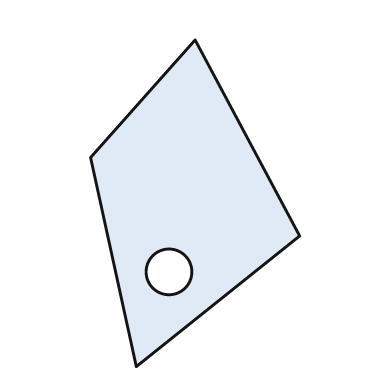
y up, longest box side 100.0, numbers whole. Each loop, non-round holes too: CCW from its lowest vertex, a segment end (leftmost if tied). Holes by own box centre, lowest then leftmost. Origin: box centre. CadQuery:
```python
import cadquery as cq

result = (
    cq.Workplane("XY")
    .moveTo(-18.0, -50.0)
    .lineTo(32.0, -10.0)
    .lineTo(0.0, 50.0)
    .lineTo(-32.0, 14.0)
    .close()
    .moveTo(-8.0, -21.0)
    .circle(7.0)
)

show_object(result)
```